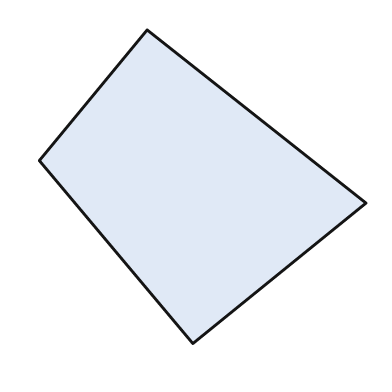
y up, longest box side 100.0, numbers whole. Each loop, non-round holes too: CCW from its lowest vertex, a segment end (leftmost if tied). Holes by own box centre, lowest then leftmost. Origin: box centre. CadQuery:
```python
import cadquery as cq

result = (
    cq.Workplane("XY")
    .moveTo(-3.0, -48.0)
    .lineTo(50.0, -5.0)
    .lineTo(-17.0, 48.0)
    .lineTo(-50.0, 8.0)
    .close()
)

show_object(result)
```